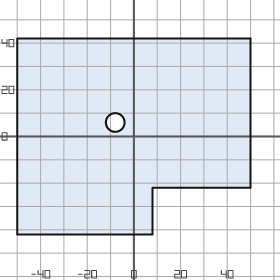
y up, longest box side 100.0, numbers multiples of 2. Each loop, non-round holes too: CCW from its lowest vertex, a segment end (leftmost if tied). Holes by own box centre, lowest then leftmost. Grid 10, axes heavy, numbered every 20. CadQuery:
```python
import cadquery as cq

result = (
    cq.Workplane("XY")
    .moveTo(-50.0, -42.0)
    .lineTo(8.0, -42.0)
    .lineTo(8.0, -22.0)
    .lineTo(50.0, -22.0)
    .lineTo(50.0, 42.0)
    .lineTo(-50.0, 42.0)
    .close()
    .moveTo(-8.0, 6.0)
    .circle(4.0)
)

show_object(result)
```